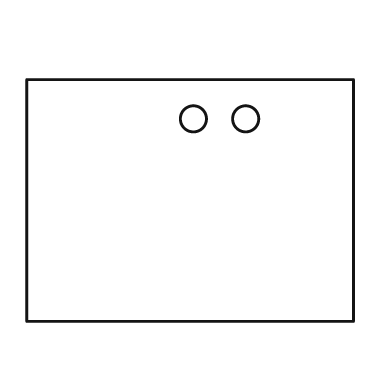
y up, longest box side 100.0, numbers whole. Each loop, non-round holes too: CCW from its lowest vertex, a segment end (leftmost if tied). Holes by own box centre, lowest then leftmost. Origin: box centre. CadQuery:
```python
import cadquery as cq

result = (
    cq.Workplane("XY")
    .moveTo(-50.0, -37.0)
    .lineTo(50.0, -37.0)
    .lineTo(50.0, 37.0)
    .lineTo(-50.0, 37.0)
    .close()
    .moveTo(1.0, 25.0)
    .circle(4.0)
    .moveTo(17.0, 25.0)
    .circle(4.0)
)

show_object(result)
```